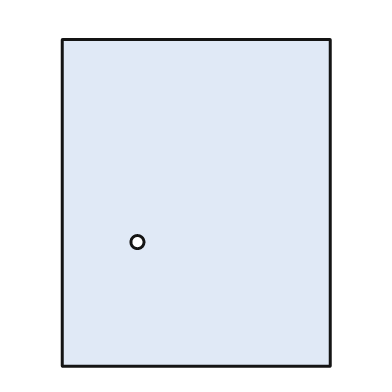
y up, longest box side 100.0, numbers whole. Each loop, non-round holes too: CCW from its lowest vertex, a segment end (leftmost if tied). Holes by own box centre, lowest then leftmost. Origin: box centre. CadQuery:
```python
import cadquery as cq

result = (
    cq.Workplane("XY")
    .moveTo(-41.0, -50.0)
    .lineTo(41.0, -50.0)
    .lineTo(41.0, 50.0)
    .lineTo(-41.0, 50.0)
    .close()
    .moveTo(-18.0, -12.0)
    .circle(2.0)
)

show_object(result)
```